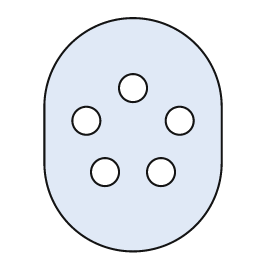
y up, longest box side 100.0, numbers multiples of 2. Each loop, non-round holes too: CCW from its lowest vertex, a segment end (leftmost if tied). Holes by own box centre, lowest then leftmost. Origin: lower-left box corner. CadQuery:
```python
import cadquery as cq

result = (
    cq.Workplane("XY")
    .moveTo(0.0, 38.0)
    .threePointArc((38.0, 0.0), (76.0, 38.0))
    .lineTo(76.0, 62.0)
    .threePointArc((38.0, 100.0), (0.0, 62.0))
    .close()
    .moveTo(26.0, 34.0)
    .circle(6.0)
    .moveTo(50.0, 34.0)
    .circle(6.0)
    .moveTo(18.0, 56.0)
    .circle(6.0)
    .moveTo(58.0, 56.0)
    .circle(6.0)
    .moveTo(38.0, 70.0)
    .circle(6.0)
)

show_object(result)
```